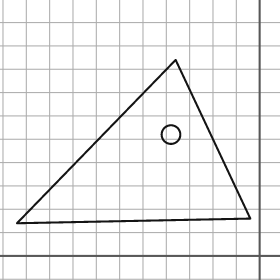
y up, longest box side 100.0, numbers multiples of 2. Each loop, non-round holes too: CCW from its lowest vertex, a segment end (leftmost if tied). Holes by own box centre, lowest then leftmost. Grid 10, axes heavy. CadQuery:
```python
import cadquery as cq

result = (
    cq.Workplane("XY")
    .moveTo(-104.0, 14.0)
    .lineTo(-4.0, 16.0)
    .lineTo(-36.0, 84.0)
    .close()
    .moveTo(-38.0, 52.0)
    .circle(4.0)
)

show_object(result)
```